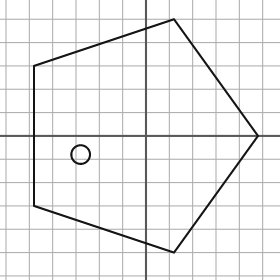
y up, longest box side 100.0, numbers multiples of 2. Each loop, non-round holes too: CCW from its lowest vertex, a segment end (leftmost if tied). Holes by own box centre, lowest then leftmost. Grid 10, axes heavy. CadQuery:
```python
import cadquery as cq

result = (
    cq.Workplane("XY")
    .moveTo(12.0, -50.0)
    .lineTo(48.0, 0.0)
    .lineTo(12.0, 50.0)
    .lineTo(-48.0, 30.0)
    .lineTo(-48.0, -30.0)
    .close()
    .moveTo(-28.0, -8.0)
    .circle(4.0)
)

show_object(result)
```